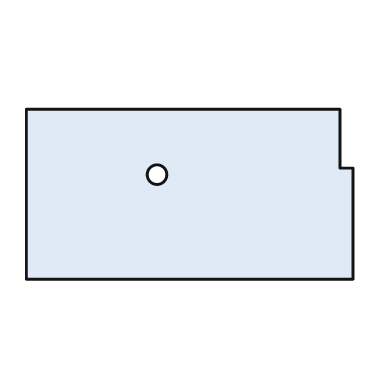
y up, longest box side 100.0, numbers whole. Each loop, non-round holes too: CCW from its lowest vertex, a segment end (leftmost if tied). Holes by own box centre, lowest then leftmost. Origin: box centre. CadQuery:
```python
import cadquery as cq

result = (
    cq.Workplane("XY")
    .moveTo(-50.0, -26.0)
    .lineTo(50.0, -26.0)
    .lineTo(50.0, 8.0)
    .lineTo(46.0, 8.0)
    .lineTo(46.0, 26.0)
    .lineTo(-50.0, 26.0)
    .close()
    .moveTo(-10.0, 6.0)
    .circle(3.0)
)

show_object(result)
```